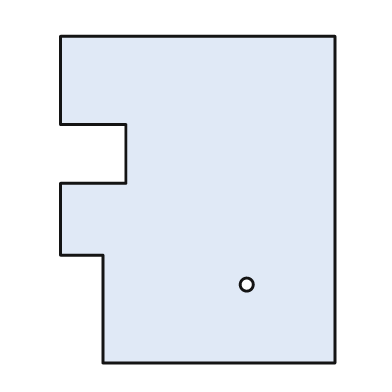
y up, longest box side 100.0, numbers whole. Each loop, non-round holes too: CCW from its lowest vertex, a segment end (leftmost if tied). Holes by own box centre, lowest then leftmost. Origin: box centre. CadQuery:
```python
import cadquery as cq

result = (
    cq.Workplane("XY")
    .moveTo(-29.0, -50.0)
    .lineTo(42.0, -50.0)
    .lineTo(42.0, 50.0)
    .lineTo(-42.0, 50.0)
    .lineTo(-42.0, 23.0)
    .lineTo(-22.0, 23.0)
    .lineTo(-22.0, 5.0)
    .lineTo(-42.0, 5.0)
    .lineTo(-42.0, -17.0)
    .lineTo(-29.0, -17.0)
    .close()
    .moveTo(15.0, -26.0)
    .circle(2.0)
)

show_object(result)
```